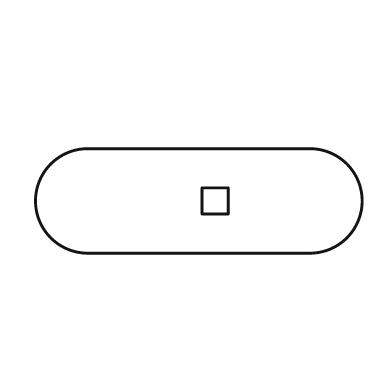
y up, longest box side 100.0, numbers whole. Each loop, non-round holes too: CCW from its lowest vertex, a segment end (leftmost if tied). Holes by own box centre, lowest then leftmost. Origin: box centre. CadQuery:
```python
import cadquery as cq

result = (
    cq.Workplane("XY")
    .moveTo(-34.0, -16.0)
    .lineTo(34.0, -16.0)
    .threePointArc((50.0, 0.0), (34.0, 16.0))
    .lineTo(-34.0, 16.0)
    .threePointArc((-50.0, 0.0), (-34.0, -16.0))
    .close()
    .moveTo(1.0, -4.0)
    .lineTo(9.0, -4.0)
    .lineTo(9.0, 4.0)
    .lineTo(1.0, 4.0)
    .close()
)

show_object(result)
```